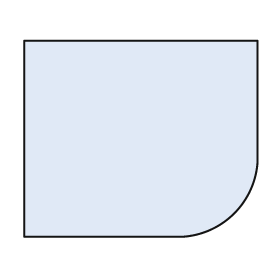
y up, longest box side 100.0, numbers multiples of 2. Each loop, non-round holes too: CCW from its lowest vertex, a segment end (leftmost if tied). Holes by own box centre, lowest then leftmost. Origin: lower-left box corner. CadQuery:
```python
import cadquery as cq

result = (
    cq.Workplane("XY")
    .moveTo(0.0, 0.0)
    .lineTo(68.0, 0.0)
    .threePointArc((90.0, 10.0), (100.0, 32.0))
    .lineTo(100.0, 84.0)
    .lineTo(0.0, 84.0)
    .close()
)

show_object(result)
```